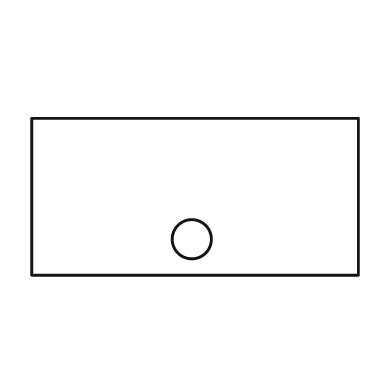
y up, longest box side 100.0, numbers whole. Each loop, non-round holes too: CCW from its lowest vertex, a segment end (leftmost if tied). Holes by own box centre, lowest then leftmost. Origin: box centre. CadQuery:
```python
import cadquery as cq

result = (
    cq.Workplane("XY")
    .moveTo(-50.0, -24.0)
    .lineTo(50.0, -24.0)
    .lineTo(50.0, 24.0)
    .lineTo(-50.0, 24.0)
    .close()
    .moveTo(-1.0, -13.0)
    .circle(6.0)
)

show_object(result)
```